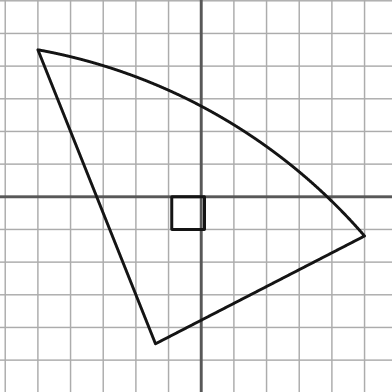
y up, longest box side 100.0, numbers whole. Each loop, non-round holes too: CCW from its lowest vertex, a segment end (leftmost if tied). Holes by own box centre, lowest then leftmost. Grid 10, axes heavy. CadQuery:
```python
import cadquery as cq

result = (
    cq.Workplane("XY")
    .moveTo(-14.0, -45.0)
    .lineTo(50.0, -12.0)
    .threePointArc((5.0, 25.0), (-50.0, 45.0))
    .close()
    .moveTo(-9.0, -10.0)
    .lineTo(1.0, -10.0)
    .lineTo(1.0, 0.0)
    .lineTo(-9.0, 0.0)
    .close()
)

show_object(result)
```